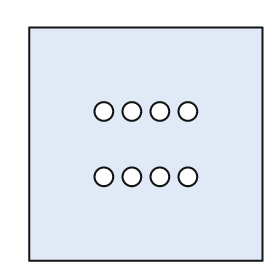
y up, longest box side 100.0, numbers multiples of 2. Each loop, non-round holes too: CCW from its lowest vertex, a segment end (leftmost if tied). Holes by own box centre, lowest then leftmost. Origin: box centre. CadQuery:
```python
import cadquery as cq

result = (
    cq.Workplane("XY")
    .moveTo(-50.0, -50.0)
    .lineTo(50.0, -50.0)
    .lineTo(50.0, 50.0)
    .lineTo(-50.0, 50.0)
    .close()
    .moveTo(-18.0, -14.0)
    .circle(4.0)
    .moveTo(-6.0, -14.0)
    .circle(4.0)
    .moveTo(6.0, -14.0)
    .circle(4.0)
    .moveTo(18.0, -14.0)
    .circle(4.0)
    .moveTo(-18.0, 14.0)
    .circle(4.0)
    .moveTo(-6.0, 14.0)
    .circle(4.0)
    .moveTo(6.0, 14.0)
    .circle(4.0)
    .moveTo(18.0, 14.0)
    .circle(4.0)
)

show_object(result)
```